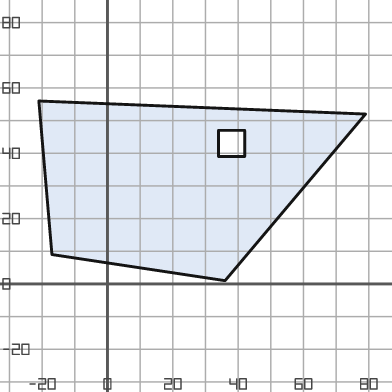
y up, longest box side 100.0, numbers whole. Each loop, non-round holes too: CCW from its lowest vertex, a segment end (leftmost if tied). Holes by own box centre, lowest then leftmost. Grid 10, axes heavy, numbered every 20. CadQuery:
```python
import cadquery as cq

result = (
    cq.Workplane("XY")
    .moveTo(36.0, 1.0)
    .lineTo(79.0, 52.0)
    .lineTo(-21.0, 56.0)
    .lineTo(-17.0, 9.0)
    .close()
    .moveTo(34.0, 39.0)
    .lineTo(42.0, 39.0)
    .lineTo(42.0, 47.0)
    .lineTo(34.0, 47.0)
    .close()
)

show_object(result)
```